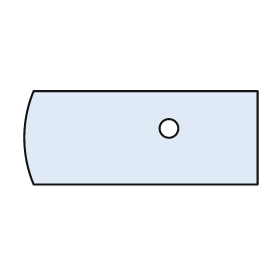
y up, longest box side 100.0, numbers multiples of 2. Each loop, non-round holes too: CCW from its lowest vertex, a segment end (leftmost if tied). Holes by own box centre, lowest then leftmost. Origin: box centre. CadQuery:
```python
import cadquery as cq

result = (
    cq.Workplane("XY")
    .moveTo(-46.0, -20.0)
    .lineTo(50.0, -20.0)
    .lineTo(50.0, 20.0)
    .lineTo(-46.0, 20.0)
    .threePointArc((-50.0, 0.0), (-46.0, -20.0))
    .close()
    .moveTo(12.0, 4.0)
    .circle(4.0)
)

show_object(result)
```